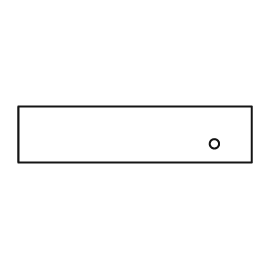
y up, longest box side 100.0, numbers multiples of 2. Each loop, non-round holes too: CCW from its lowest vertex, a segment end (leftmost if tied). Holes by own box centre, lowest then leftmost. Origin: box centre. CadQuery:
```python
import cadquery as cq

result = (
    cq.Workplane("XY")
    .moveTo(-50.0, -12.0)
    .lineTo(50.0, -12.0)
    .lineTo(50.0, 12.0)
    .lineTo(-50.0, 12.0)
    .close()
    .moveTo(34.0, -4.0)
    .circle(2.0)
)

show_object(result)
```